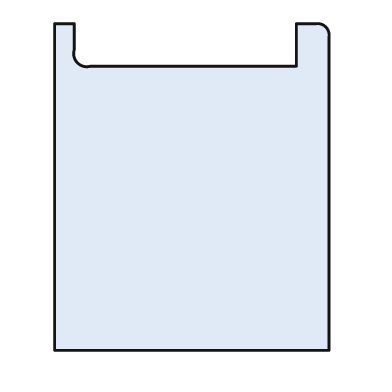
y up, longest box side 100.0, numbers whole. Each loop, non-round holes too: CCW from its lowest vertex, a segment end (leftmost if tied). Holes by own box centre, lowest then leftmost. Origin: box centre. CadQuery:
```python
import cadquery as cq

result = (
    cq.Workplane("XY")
    .moveTo(-42.0, -50.0)
    .lineTo(42.0, -50.0)
    .lineTo(42.0, 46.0)
    .threePointArc((41.0, 49.0), (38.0, 50.0))
    .lineTo(32.0, 50.0)
    .lineTo(32.0, 37.0)
    .lineTo(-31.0, 37.0)
    .threePointArc((-35.0, 38.0), (-36.0, 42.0))
    .lineTo(-36.0, 50.0)
    .lineTo(-42.0, 50.0)
    .close()
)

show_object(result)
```